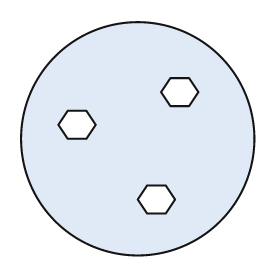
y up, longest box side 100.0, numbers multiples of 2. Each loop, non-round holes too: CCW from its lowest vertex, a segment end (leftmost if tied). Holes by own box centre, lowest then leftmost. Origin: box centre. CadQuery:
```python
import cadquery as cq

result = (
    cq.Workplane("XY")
    .moveTo(0.0, 0.0)
    .circle(50.0)
    .moveTo(4.0, -32.0)
    .lineTo(12.0, -32.0)
    .lineTo(16.0, -26.0)
    .lineTo(12.0, -20.0)
    .lineTo(4.0, -20.0)
    .lineTo(0.0, -26.0)
    .close()
    .moveTo(-30.0, 0.0)
    .lineTo(-22.0, 0.0)
    .lineTo(-18.0, 6.0)
    .lineTo(-22.0, 12.0)
    .lineTo(-30.0, 12.0)
    .lineTo(-34.0, 6.0)
    .close()
    .moveTo(14.0, 14.0)
    .lineTo(22.0, 14.0)
    .lineTo(26.0, 20.0)
    .lineTo(22.0, 26.0)
    .lineTo(14.0, 26.0)
    .lineTo(10.0, 20.0)
    .close()
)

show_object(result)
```